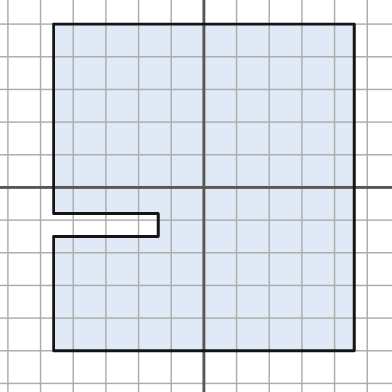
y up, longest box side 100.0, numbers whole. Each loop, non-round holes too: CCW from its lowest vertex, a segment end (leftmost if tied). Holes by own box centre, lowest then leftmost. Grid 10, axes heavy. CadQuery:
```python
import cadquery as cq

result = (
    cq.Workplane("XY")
    .moveTo(-46.0, -50.0)
    .lineTo(46.0, -50.0)
    .lineTo(46.0, 50.0)
    .lineTo(-46.0, 50.0)
    .lineTo(-46.0, -8.0)
    .lineTo(-14.0, -8.0)
    .lineTo(-14.0, -15.0)
    .lineTo(-46.0, -15.0)
    .close()
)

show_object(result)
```